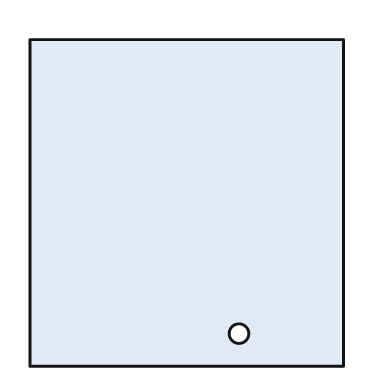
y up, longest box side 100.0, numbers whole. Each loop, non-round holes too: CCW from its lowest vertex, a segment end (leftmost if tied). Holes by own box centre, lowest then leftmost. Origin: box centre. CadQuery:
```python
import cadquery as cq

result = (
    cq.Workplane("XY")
    .moveTo(-48.0, -50.0)
    .lineTo(48.0, -50.0)
    .lineTo(48.0, 50.0)
    .lineTo(-48.0, 50.0)
    .close()
    .moveTo(16.0, -40.0)
    .circle(3.0)
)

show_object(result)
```